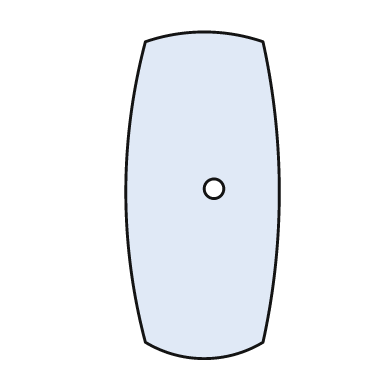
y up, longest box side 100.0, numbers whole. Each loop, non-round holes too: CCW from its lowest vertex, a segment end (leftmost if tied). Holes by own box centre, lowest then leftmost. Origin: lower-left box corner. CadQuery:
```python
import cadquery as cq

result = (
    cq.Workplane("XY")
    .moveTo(6.0, 5.0)
    .threePointArc((24.0, 0.0), (42.0, 5.0))
    .threePointArc((47.0, 51.0), (42.0, 97.0))
    .threePointArc((24.0, 100.0), (6.0, 97.0))
    .threePointArc((0.0, 51.0), (6.0, 5.0))
    .close()
    .moveTo(27.0, 52.0)
    .circle(3.0)
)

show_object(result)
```